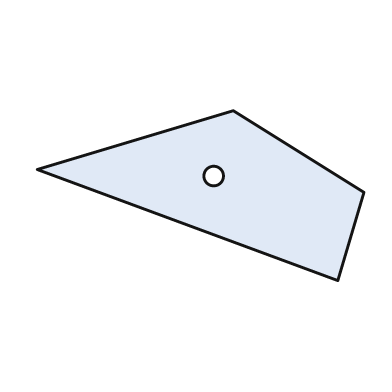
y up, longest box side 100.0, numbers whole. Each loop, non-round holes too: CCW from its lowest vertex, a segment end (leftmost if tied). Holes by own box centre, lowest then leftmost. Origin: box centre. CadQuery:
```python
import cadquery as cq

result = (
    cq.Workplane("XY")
    .moveTo(42.0, -26.0)
    .lineTo(50.0, 1.0)
    .lineTo(10.0, 26.0)
    .lineTo(-50.0, 8.0)
    .close()
    .moveTo(4.0, 6.0)
    .circle(3.0)
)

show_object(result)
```